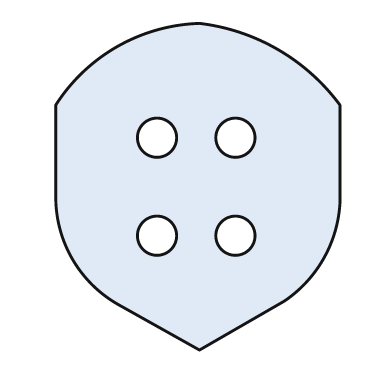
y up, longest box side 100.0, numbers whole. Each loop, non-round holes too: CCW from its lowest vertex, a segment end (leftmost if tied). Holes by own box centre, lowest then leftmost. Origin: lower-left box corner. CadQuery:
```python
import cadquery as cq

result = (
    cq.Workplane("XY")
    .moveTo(44.0, 0.0)
    .lineTo(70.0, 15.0)
    .threePointArc((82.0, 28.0), (87.0, 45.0))
    .lineTo(87.0, 75.0)
    .threePointArc((68.0, 92.0), (44.0, 100.0))
    .threePointArc((19.0, 93.0), (0.0, 75.0))
    .lineTo(0.0, 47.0)
    .threePointArc((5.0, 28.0), (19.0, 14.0))
    .close()
    .moveTo(31.0, 35.0)
    .circle(6.0)
    .moveTo(55.0, 35.0)
    .circle(6.0)
    .moveTo(31.0, 65.0)
    .circle(6.0)
    .moveTo(55.0, 65.0)
    .circle(6.0)
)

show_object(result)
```